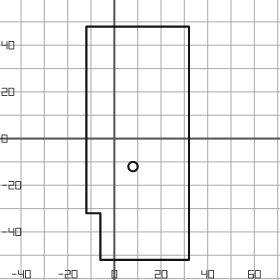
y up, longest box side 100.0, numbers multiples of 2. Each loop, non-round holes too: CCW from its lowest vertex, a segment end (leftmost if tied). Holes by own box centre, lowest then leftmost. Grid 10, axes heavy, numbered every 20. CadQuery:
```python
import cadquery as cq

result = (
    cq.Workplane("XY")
    .moveTo(-6.0, -52.0)
    .lineTo(32.0, -52.0)
    .lineTo(32.0, 48.0)
    .lineTo(-12.0, 48.0)
    .lineTo(-12.0, -32.0)
    .lineTo(-6.0, -32.0)
    .close()
    .moveTo(8.0, -12.0)
    .circle(2.0)
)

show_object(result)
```